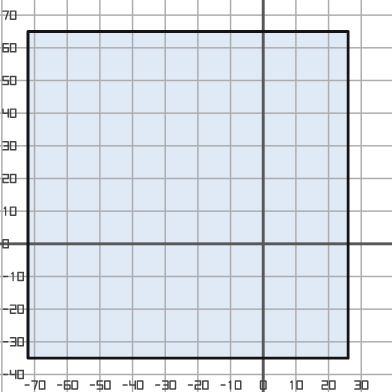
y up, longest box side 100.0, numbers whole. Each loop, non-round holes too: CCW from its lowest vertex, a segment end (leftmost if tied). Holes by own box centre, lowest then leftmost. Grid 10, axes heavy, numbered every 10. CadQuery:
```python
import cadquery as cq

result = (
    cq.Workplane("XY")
    .moveTo(-72.0, -35.0)
    .lineTo(26.0, -35.0)
    .lineTo(26.0, 65.0)
    .lineTo(-72.0, 65.0)
    .close()
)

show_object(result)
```